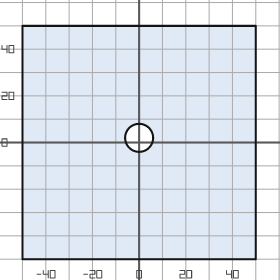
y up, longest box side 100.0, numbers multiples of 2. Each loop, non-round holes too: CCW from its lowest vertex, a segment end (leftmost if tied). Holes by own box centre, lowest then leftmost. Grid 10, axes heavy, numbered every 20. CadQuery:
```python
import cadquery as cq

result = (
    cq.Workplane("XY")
    .moveTo(-50.0, -50.0)
    .lineTo(50.0, -50.0)
    .lineTo(50.0, 50.0)
    .lineTo(-50.0, 50.0)
    .close()
    .moveTo(0.0, 2.0)
    .circle(6.0)
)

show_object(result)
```